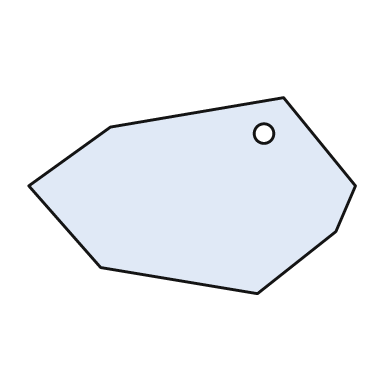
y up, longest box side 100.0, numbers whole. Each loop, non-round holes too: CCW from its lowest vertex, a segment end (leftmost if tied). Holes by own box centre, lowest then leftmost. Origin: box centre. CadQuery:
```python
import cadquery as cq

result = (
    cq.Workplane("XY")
    .moveTo(20.0, -30.0)
    .lineTo(44.0, -11.0)
    .lineTo(50.0, 3.0)
    .lineTo(28.0, 30.0)
    .lineTo(-25.0, 21.0)
    .lineTo(-50.0, 3.0)
    .lineTo(-28.0, -22.0)
    .close()
    .moveTo(22.0, 19.0)
    .circle(3.0)
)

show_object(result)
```